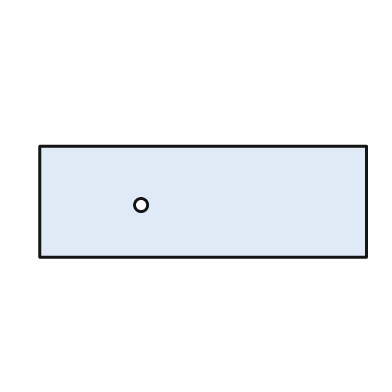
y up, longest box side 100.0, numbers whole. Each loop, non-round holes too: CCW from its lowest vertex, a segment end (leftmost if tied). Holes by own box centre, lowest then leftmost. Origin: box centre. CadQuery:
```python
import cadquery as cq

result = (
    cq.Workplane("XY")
    .moveTo(-50.0, -17.0)
    .lineTo(50.0, -17.0)
    .lineTo(50.0, 17.0)
    .lineTo(-50.0, 17.0)
    .close()
    .moveTo(-19.0, -1.0)
    .circle(2.0)
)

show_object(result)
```